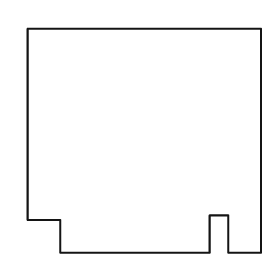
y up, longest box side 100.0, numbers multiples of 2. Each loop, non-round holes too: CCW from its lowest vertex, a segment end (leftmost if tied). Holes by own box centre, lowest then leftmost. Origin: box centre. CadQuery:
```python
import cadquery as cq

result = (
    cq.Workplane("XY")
    .moveTo(-36.0, -48.0)
    .lineTo(28.0, -48.0)
    .lineTo(28.0, -32.0)
    .lineTo(36.0, -32.0)
    .lineTo(36.0, -48.0)
    .lineTo(50.0, -48.0)
    .lineTo(50.0, 48.0)
    .lineTo(-50.0, 48.0)
    .lineTo(-50.0, -34.0)
    .lineTo(-36.0, -34.0)
    .close()
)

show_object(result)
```